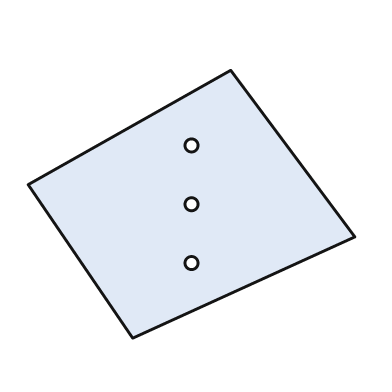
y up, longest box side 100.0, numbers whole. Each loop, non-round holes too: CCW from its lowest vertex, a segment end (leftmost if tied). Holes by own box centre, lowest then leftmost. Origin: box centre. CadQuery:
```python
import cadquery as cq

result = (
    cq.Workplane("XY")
    .moveTo(-18.0, -41.0)
    .lineTo(50.0, -10.0)
    .lineTo(12.0, 41.0)
    .lineTo(-50.0, 6.0)
    .close()
    .moveTo(0.0, -18.0)
    .circle(2.0)
    .moveTo(0.0, 0.0)
    .circle(2.0)
    .moveTo(0.0, 18.0)
    .circle(2.0)
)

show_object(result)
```